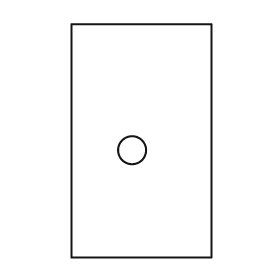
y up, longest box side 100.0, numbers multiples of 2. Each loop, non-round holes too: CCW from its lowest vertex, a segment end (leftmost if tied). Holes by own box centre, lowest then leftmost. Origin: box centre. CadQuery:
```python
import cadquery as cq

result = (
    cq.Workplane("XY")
    .moveTo(-30.0, -50.0)
    .lineTo(30.0, -50.0)
    .lineTo(30.0, 50.0)
    .lineTo(-30.0, 50.0)
    .close()
    .moveTo(-4.0, -4.0)
    .circle(6.0)
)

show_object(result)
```